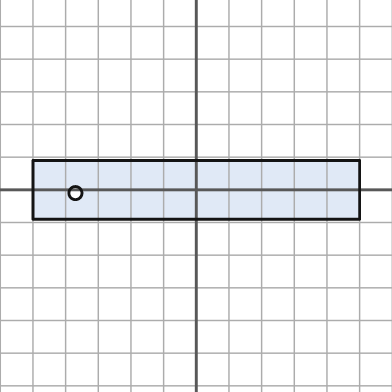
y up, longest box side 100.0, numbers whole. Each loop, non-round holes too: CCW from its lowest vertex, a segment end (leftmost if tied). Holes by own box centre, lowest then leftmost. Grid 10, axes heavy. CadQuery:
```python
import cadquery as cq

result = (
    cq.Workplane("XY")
    .moveTo(-50.0, -9.0)
    .lineTo(50.0, -9.0)
    .lineTo(50.0, 9.0)
    .lineTo(-50.0, 9.0)
    .close()
    .moveTo(-37.0, -1.0)
    .circle(2.0)
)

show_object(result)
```